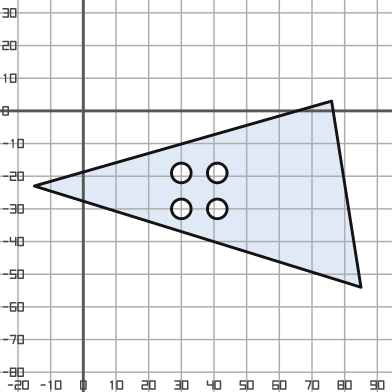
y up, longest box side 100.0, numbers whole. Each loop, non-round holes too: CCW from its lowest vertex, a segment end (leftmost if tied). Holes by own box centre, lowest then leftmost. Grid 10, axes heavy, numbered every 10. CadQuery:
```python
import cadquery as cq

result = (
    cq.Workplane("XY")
    .moveTo(85.0, -54.0)
    .lineTo(76.0, 3.0)
    .lineTo(-15.0, -23.0)
    .close()
    .moveTo(30.0, -30.0)
    .circle(3.0)
    .moveTo(41.0, -30.0)
    .circle(3.0)
    .moveTo(30.0, -19.0)
    .circle(3.0)
    .moveTo(41.0, -19.0)
    .circle(3.0)
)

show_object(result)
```